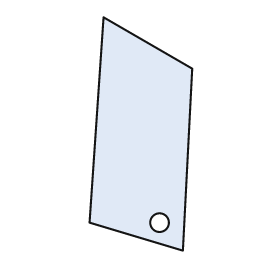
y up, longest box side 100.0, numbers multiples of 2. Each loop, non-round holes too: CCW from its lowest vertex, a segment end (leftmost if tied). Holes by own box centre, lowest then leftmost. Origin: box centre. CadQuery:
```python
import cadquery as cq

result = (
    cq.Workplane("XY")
    .moveTo(18.0, -50.0)
    .lineTo(22.0, 28.0)
    .lineTo(-16.0, 50.0)
    .lineTo(-22.0, -38.0)
    .close()
    .moveTo(8.0, -38.0)
    .circle(4.0)
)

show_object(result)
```